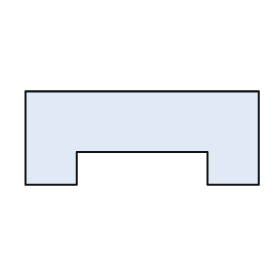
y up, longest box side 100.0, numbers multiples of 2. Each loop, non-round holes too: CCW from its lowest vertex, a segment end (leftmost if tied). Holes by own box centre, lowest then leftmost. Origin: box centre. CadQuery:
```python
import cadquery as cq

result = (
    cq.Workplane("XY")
    .moveTo(-50.0, -20.0)
    .lineTo(-28.0, -20.0)
    .lineTo(-28.0, -6.0)
    .lineTo(28.0, -6.0)
    .lineTo(28.0, -20.0)
    .lineTo(50.0, -20.0)
    .lineTo(50.0, 20.0)
    .lineTo(-50.0, 20.0)
    .close()
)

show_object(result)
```